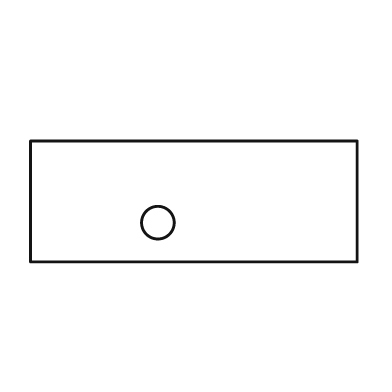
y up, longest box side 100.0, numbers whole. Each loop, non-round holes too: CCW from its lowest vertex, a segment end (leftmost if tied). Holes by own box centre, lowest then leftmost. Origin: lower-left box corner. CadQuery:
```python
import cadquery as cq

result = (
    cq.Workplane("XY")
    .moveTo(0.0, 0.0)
    .lineTo(100.0, 0.0)
    .lineTo(100.0, 37.0)
    .lineTo(0.0, 37.0)
    .close()
    .moveTo(39.0, 12.0)
    .circle(5.0)
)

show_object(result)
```